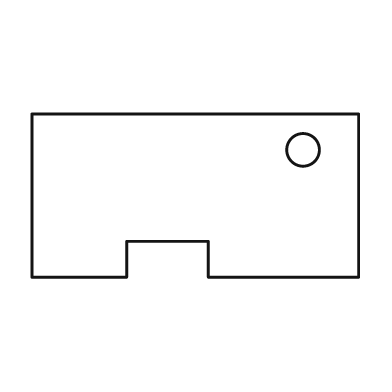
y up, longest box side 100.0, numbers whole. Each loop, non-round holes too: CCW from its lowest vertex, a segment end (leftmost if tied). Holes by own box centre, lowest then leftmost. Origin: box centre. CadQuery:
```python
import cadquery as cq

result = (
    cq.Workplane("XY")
    .moveTo(-50.0, -25.0)
    .lineTo(-21.0, -25.0)
    .lineTo(-21.0, -14.0)
    .lineTo(4.0, -14.0)
    .lineTo(4.0, -25.0)
    .lineTo(50.0, -25.0)
    .lineTo(50.0, 25.0)
    .lineTo(-50.0, 25.0)
    .close()
    .moveTo(33.0, 14.0)
    .circle(5.0)
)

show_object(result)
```